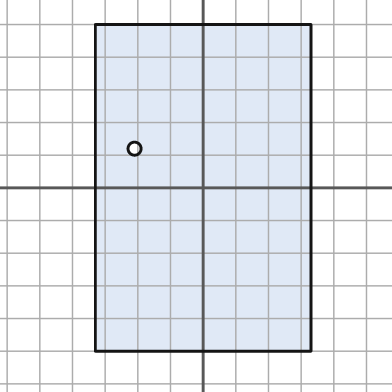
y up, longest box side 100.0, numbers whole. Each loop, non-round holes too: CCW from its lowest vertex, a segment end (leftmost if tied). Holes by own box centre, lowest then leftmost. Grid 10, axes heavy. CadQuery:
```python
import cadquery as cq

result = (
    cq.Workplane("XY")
    .moveTo(-33.0, -50.0)
    .lineTo(33.0, -50.0)
    .lineTo(33.0, 50.0)
    .lineTo(-33.0, 50.0)
    .close()
    .moveTo(-21.0, 12.0)
    .circle(2.0)
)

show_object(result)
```